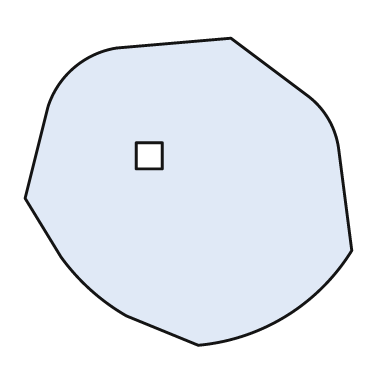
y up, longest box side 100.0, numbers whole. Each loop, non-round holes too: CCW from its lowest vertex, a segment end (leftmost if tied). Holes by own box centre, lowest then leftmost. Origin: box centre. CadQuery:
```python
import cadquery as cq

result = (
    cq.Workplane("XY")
    .moveTo(3.0, -47.0)
    .threePointArc((30.0, -38.0), (50.0, -18.0))
    .lineTo(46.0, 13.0)
    .threePointArc((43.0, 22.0), (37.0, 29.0))
    .lineTo(13.0, 47.0)
    .lineTo(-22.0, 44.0)
    .threePointArc((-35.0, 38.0), (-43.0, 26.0))
    .lineTo(-50.0, -2.0)
    .lineTo(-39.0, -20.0)
    .threePointArc((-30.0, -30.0), (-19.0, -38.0))
    .close()
    .moveTo(-16.0, 7.0)
    .lineTo(-8.0, 7.0)
    .lineTo(-8.0, 15.0)
    .lineTo(-16.0, 15.0)
    .close()
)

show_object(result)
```